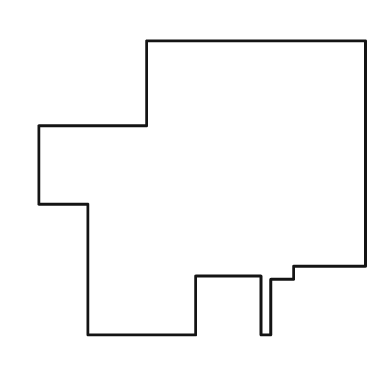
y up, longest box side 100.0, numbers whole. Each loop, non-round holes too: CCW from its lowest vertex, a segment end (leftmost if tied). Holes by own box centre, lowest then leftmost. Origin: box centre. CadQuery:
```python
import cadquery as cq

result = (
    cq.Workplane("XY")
    .moveTo(-35.0, -45.0)
    .lineTo(-2.0, -45.0)
    .lineTo(-2.0, -27.0)
    .lineTo(18.0, -27.0)
    .lineTo(18.0, -45.0)
    .lineTo(21.0, -45.0)
    .lineTo(21.0, -28.0)
    .lineTo(28.0, -28.0)
    .lineTo(28.0, -24.0)
    .lineTo(50.0, -24.0)
    .lineTo(50.0, 45.0)
    .lineTo(-17.0, 45.0)
    .lineTo(-17.0, 19.0)
    .lineTo(-50.0, 19.0)
    .lineTo(-50.0, -5.0)
    .lineTo(-35.0, -5.0)
    .close()
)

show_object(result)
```